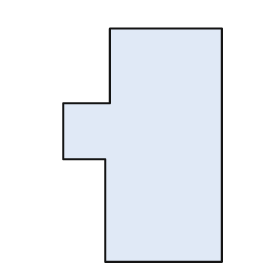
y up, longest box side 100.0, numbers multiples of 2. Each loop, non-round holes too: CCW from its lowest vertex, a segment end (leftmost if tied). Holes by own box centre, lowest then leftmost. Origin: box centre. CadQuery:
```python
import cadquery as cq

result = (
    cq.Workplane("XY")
    .moveTo(-16.0, -50.0)
    .lineTo(34.0, -50.0)
    .lineTo(34.0, 50.0)
    .lineTo(-14.0, 50.0)
    .lineTo(-14.0, 18.0)
    .lineTo(-34.0, 18.0)
    .lineTo(-34.0, -6.0)
    .lineTo(-16.0, -6.0)
    .close()
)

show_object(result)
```